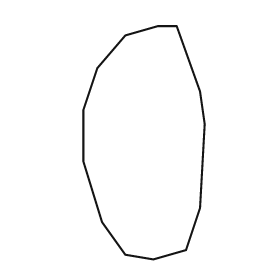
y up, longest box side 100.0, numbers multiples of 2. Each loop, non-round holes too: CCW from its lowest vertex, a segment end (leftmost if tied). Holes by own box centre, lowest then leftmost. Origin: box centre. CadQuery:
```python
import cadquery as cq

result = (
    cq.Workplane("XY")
    .moveTo(4.0, -50.0)
    .lineTo(18.0, -46.0)
    .lineTo(24.0, -28.0)
    .lineTo(26.0, 8.0)
    .lineTo(24.0, 22.0)
    .lineTo(14.0, 50.0)
    .lineTo(6.0, 50.0)
    .lineTo(-8.0, 46.0)
    .lineTo(-20.0, 32.0)
    .lineTo(-26.0, 14.0)
    .lineTo(-26.0, -8.0)
    .lineTo(-18.0, -34.0)
    .lineTo(-8.0, -48.0)
    .close()
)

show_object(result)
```